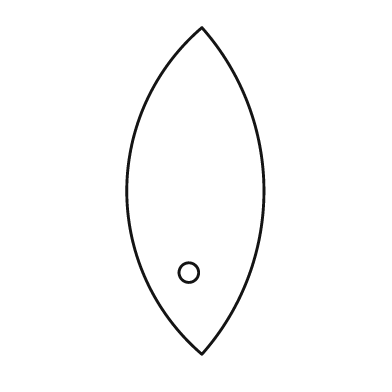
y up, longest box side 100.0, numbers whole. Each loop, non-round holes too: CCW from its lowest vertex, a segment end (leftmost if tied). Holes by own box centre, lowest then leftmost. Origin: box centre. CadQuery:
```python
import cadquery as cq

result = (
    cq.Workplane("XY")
    .moveTo(2.0, -50.0)
    .threePointArc((21.0, 0.0), (2.0, 50.0))
    .threePointArc((-21.0, 0.0), (2.0, -50.0))
    .close()
    .moveTo(-2.0, -25.0)
    .circle(3.0)
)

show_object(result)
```